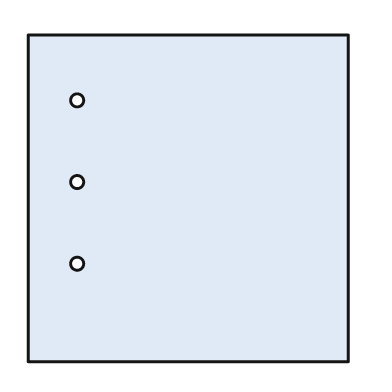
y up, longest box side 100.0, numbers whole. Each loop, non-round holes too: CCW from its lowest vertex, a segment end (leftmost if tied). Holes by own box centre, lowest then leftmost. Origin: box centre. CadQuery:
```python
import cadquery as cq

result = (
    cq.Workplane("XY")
    .moveTo(-49.0, -50.0)
    .lineTo(49.0, -50.0)
    .lineTo(49.0, 50.0)
    .lineTo(-49.0, 50.0)
    .close()
    .moveTo(-34.0, -20.0)
    .circle(2.0)
    .moveTo(-34.0, 5.0)
    .circle(2.0)
    .moveTo(-34.0, 30.0)
    .circle(2.0)
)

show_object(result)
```